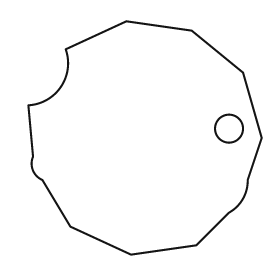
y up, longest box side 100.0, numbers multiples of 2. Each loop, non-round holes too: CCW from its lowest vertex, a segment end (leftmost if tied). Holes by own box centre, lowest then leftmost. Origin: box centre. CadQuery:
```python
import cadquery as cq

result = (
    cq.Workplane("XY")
    .moveTo(-6.0, -50.0)
    .lineTo(22.0, -46.0)
    .lineTo(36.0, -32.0)
    .threePointArc((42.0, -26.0), (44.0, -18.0))
    .lineTo(50.0, 0.0)
    .lineTo(42.0, 28.0)
    .lineTo(20.0, 46.0)
    .lineTo(-8.0, 50.0)
    .lineTo(-34.0, 38.0)
    .threePointArc((-36.0, 22.0), (-50.0, 14.0))
    .lineTo(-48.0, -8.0)
    .threePointArc((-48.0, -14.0), (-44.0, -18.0))
    .lineTo(-32.0, -38.0)
    .close()
    .moveTo(36.0, 4.0)
    .circle(6.0)
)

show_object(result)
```